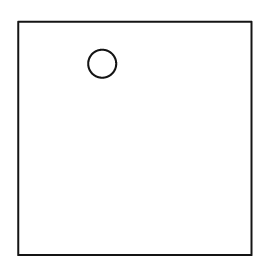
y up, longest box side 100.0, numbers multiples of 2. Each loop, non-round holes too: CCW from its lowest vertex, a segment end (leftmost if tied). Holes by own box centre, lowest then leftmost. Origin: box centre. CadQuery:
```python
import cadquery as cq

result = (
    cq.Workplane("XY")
    .moveTo(-50.0, -50.0)
    .lineTo(50.0, -50.0)
    .lineTo(50.0, 50.0)
    .lineTo(-50.0, 50.0)
    .close()
    .moveTo(-14.0, 32.0)
    .circle(6.0)
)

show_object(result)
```